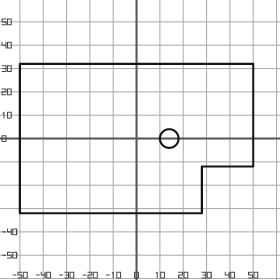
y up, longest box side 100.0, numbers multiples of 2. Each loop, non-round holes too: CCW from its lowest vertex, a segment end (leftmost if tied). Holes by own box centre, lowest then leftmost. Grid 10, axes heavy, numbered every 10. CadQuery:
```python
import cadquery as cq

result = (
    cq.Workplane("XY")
    .moveTo(-50.0, -32.0)
    .lineTo(28.0, -32.0)
    .lineTo(28.0, -12.0)
    .lineTo(50.0, -12.0)
    .lineTo(50.0, 32.0)
    .lineTo(-50.0, 32.0)
    .close()
    .moveTo(14.0, 0.0)
    .circle(4.0)
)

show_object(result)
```